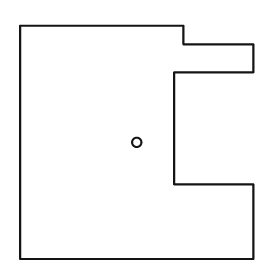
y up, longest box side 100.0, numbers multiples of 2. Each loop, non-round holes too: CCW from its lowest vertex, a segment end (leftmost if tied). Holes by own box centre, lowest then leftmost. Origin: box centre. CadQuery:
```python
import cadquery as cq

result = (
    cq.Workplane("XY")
    .moveTo(-50.0, -50.0)
    .lineTo(50.0, -50.0)
    .lineTo(50.0, -18.0)
    .lineTo(16.0, -18.0)
    .lineTo(16.0, 30.0)
    .lineTo(50.0, 30.0)
    .lineTo(50.0, 42.0)
    .lineTo(20.0, 42.0)
    .lineTo(20.0, 50.0)
    .lineTo(-50.0, 50.0)
    .close()
    .moveTo(0.0, 0.0)
    .circle(2.0)
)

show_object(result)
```